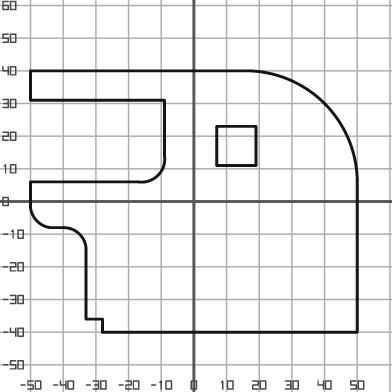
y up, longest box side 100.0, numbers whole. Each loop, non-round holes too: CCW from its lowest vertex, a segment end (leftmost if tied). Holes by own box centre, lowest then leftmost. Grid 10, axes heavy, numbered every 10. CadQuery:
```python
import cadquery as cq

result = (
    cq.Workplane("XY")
    .moveTo(-28.0, -40.0)
    .lineTo(50.0, -40.0)
    .lineTo(50.0, 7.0)
    .threePointArc((40.0, 30.0), (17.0, 40.0))
    .lineTo(-50.0, 40.0)
    .lineTo(-50.0, 31.0)
    .lineTo(-9.0, 31.0)
    .lineTo(-9.0, 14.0)
    .threePointArc((-11.0, 8.0), (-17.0, 6.0))
    .lineTo(-50.0, 6.0)
    .lineTo(-50.0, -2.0)
    .threePointArc((-48.0, -6.0), (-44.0, -8.0))
    .lineTo(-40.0, -8.0)
    .threePointArc((-35.0, -10.0), (-33.0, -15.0))
    .lineTo(-33.0, -36.0)
    .lineTo(-28.0, -36.0)
    .close()
    .moveTo(7.0, 11.0)
    .lineTo(19.0, 11.0)
    .lineTo(19.0, 23.0)
    .lineTo(7.0, 23.0)
    .close()
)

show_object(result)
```